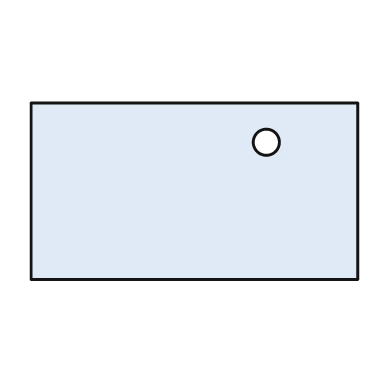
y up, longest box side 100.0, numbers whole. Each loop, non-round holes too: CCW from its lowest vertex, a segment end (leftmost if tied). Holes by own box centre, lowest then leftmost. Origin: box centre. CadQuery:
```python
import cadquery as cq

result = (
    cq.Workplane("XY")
    .moveTo(-50.0, -27.0)
    .lineTo(50.0, -27.0)
    .lineTo(50.0, 27.0)
    .lineTo(-50.0, 27.0)
    .close()
    .moveTo(22.0, 15.0)
    .circle(4.0)
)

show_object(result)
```